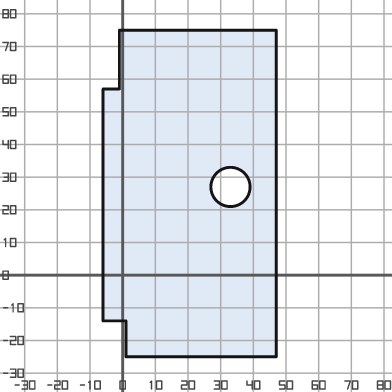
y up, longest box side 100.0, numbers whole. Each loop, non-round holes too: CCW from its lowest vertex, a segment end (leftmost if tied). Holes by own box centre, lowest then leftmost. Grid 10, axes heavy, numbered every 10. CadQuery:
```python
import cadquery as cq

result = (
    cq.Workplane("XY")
    .moveTo(1.0, -25.0)
    .lineTo(47.0, -25.0)
    .lineTo(47.0, 75.0)
    .lineTo(-1.0, 75.0)
    .lineTo(-1.0, 57.0)
    .lineTo(-6.0, 57.0)
    .lineTo(-6.0, -14.0)
    .lineTo(1.0, -14.0)
    .close()
    .moveTo(33.0, 27.0)
    .circle(6.0)
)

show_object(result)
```